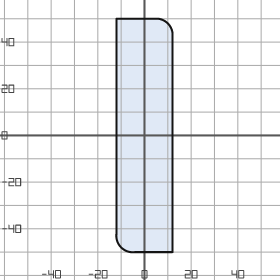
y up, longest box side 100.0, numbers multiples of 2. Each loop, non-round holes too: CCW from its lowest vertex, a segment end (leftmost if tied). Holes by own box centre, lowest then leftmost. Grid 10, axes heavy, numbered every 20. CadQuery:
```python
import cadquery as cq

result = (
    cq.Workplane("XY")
    .moveTo(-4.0, -50.0)
    .lineTo(12.0, -50.0)
    .lineTo(12.0, 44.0)
    .threePointArc((10.0, 48.0), (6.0, 50.0))
    .lineTo(-12.0, 50.0)
    .lineTo(-12.0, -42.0)
    .threePointArc((-10.0, -48.0), (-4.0, -50.0))
    .close()
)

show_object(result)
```